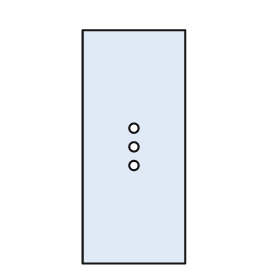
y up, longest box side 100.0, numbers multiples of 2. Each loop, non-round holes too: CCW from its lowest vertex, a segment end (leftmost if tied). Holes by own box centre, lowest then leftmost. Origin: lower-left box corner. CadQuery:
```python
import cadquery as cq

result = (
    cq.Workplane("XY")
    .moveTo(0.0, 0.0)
    .lineTo(44.0, 0.0)
    .lineTo(44.0, 100.0)
    .lineTo(0.0, 100.0)
    .close()
    .moveTo(22.0, 42.0)
    .circle(2.0)
    .moveTo(22.0, 50.0)
    .circle(2.0)
    .moveTo(22.0, 58.0)
    .circle(2.0)
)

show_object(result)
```